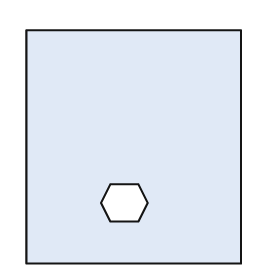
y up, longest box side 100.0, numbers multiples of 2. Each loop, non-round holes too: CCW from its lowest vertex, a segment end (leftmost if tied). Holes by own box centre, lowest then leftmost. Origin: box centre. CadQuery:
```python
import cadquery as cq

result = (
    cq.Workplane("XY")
    .moveTo(-46.0, -50.0)
    .lineTo(46.0, -50.0)
    .lineTo(46.0, 50.0)
    .lineTo(-46.0, 50.0)
    .close()
    .moveTo(-10.0, -32.0)
    .lineTo(2.0, -32.0)
    .lineTo(6.0, -24.0)
    .lineTo(2.0, -16.0)
    .lineTo(-10.0, -16.0)
    .lineTo(-14.0, -24.0)
    .close()
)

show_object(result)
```